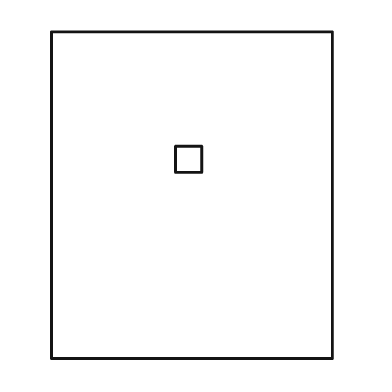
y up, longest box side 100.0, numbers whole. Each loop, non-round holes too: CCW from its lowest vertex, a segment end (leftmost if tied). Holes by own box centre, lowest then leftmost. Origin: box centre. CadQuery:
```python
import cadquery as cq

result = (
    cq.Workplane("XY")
    .moveTo(-43.0, -50.0)
    .lineTo(43.0, -50.0)
    .lineTo(43.0, 50.0)
    .lineTo(-43.0, 50.0)
    .close()
    .moveTo(-5.0, 7.0)
    .lineTo(3.0, 7.0)
    .lineTo(3.0, 15.0)
    .lineTo(-5.0, 15.0)
    .close()
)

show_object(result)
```